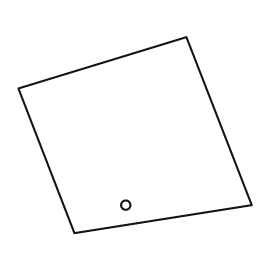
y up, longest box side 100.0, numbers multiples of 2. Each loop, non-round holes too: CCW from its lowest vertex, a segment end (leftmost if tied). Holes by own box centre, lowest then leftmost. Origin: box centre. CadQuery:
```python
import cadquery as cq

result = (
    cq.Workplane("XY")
    .moveTo(-26.0, -42.0)
    .lineTo(50.0, -30.0)
    .lineTo(22.0, 42.0)
    .lineTo(-50.0, 20.0)
    .close()
    .moveTo(-4.0, -30.0)
    .circle(2.0)
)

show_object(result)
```